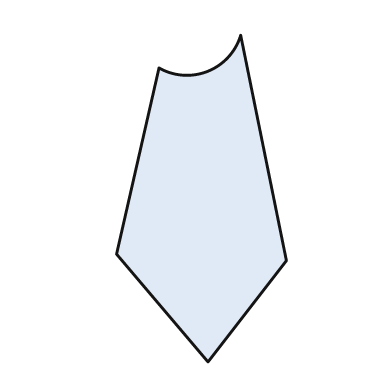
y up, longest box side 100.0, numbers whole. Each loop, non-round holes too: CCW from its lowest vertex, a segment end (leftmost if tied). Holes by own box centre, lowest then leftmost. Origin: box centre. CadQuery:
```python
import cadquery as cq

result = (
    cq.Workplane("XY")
    .moveTo(2.0, -50.0)
    .lineTo(26.0, -19.0)
    .lineTo(12.0, 50.0)
    .threePointArc((2.0, 39.0), (-13.0, 40.0))
    .lineTo(-26.0, -17.0)
    .close()
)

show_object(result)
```